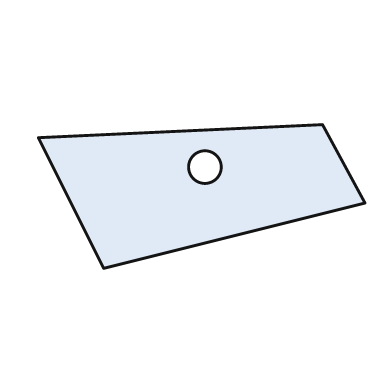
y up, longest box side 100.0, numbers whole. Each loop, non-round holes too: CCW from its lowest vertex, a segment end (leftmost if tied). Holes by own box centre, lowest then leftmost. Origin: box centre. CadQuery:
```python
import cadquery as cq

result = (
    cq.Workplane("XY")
    .moveTo(-30.0, -22.0)
    .lineTo(50.0, -2.0)
    .lineTo(37.0, 22.0)
    .lineTo(-50.0, 18.0)
    .close()
    .moveTo(1.0, 9.0)
    .circle(5.0)
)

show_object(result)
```